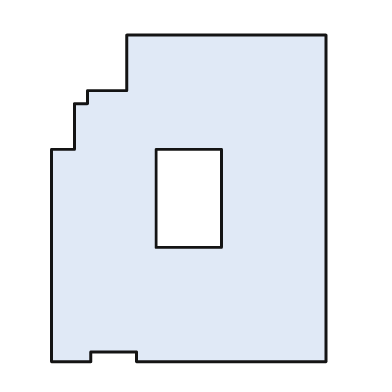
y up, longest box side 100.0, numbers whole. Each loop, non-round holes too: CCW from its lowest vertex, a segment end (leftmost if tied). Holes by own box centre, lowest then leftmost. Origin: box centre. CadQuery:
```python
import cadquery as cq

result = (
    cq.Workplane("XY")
    .moveTo(-42.0, -50.0)
    .lineTo(-30.0, -50.0)
    .lineTo(-30.0, -47.0)
    .lineTo(-16.0, -47.0)
    .lineTo(-16.0, -50.0)
    .lineTo(42.0, -50.0)
    .lineTo(42.0, 50.0)
    .lineTo(-19.0, 50.0)
    .lineTo(-19.0, 33.0)
    .lineTo(-31.0, 33.0)
    .lineTo(-31.0, 29.0)
    .lineTo(-35.0, 29.0)
    .lineTo(-35.0, 15.0)
    .lineTo(-42.0, 15.0)
    .close()
    .moveTo(-10.0, -15.0)
    .lineTo(10.0, -15.0)
    .lineTo(10.0, 15.0)
    .lineTo(-10.0, 15.0)
    .close()
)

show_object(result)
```